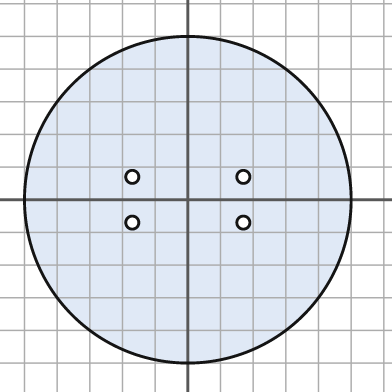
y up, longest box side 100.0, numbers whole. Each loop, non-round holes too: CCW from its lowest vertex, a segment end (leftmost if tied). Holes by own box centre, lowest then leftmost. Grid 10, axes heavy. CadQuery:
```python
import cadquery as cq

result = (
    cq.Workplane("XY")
    .moveTo(0.0, 0.0)
    .circle(50.0)
    .moveTo(-17.0, -7.0)
    .circle(2.0)
    .moveTo(17.0, -7.0)
    .circle(2.0)
    .moveTo(-17.0, 7.0)
    .circle(2.0)
    .moveTo(17.0, 7.0)
    .circle(2.0)
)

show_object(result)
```